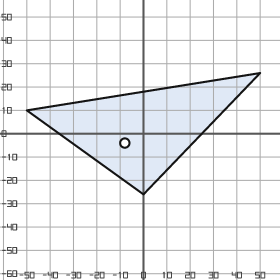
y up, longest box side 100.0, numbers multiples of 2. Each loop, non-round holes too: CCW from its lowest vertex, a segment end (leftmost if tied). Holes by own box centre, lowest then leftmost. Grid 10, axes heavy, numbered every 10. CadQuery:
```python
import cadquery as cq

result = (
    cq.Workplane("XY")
    .moveTo(0.0, -26.0)
    .lineTo(50.0, 26.0)
    .lineTo(-50.0, 10.0)
    .close()
    .moveTo(-8.0, -4.0)
    .circle(2.0)
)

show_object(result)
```